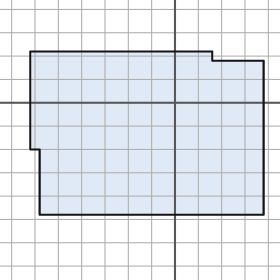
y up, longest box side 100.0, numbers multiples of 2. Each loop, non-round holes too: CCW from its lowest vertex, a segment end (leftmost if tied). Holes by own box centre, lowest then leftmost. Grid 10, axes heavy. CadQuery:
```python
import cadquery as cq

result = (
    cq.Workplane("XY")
    .moveTo(-58.0, -48.0)
    .lineTo(38.0, -48.0)
    .lineTo(38.0, 18.0)
    .lineTo(16.0, 18.0)
    .lineTo(16.0, 22.0)
    .lineTo(-62.0, 22.0)
    .lineTo(-62.0, -20.0)
    .lineTo(-58.0, -20.0)
    .close()
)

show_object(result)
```